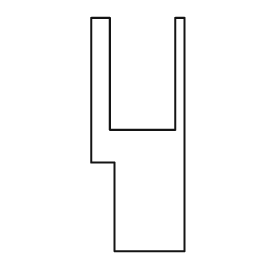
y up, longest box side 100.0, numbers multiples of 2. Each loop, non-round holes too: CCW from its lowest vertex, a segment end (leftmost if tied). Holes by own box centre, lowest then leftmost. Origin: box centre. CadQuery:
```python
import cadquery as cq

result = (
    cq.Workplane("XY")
    .moveTo(-10.0, -50.0)
    .lineTo(20.0, -50.0)
    .lineTo(20.0, 50.0)
    .lineTo(16.0, 50.0)
    .lineTo(16.0, 2.0)
    .lineTo(-12.0, 2.0)
    .lineTo(-12.0, 50.0)
    .lineTo(-20.0, 50.0)
    .lineTo(-20.0, -12.0)
    .lineTo(-10.0, -12.0)
    .close()
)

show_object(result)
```